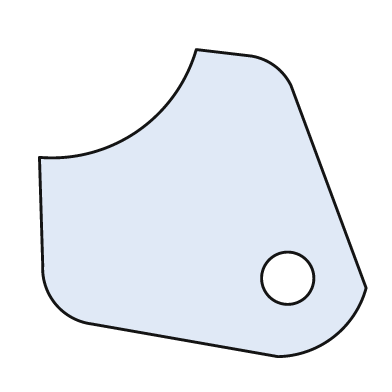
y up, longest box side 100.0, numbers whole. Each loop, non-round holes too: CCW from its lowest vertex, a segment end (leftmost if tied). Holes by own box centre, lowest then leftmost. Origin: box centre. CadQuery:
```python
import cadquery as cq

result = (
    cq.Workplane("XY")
    .moveTo(23.0, -47.0)
    .threePointArc((40.0, -41.0), (50.0, -26.0))
    .lineTo(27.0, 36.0)
    .threePointArc((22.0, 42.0), (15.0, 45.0))
    .lineTo(-2.0, 47.0)
    .threePointArc((-20.0, 22.0), (-50.0, 14.0))
    .lineTo(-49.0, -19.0)
    .threePointArc((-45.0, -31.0), (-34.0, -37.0))
    .close()
    .moveTo(26.0, -23.0)
    .circle(8.0)
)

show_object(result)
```